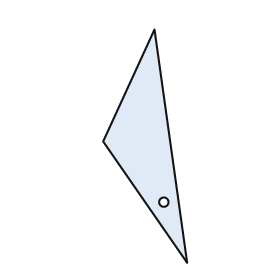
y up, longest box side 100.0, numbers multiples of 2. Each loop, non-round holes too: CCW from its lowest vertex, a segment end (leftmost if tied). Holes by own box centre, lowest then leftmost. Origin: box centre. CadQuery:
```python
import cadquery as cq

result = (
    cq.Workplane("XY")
    .moveTo(18.0, -50.0)
    .lineTo(4.0, 50.0)
    .lineTo(-18.0, 2.0)
    .close()
    .moveTo(8.0, -24.0)
    .circle(2.0)
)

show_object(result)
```